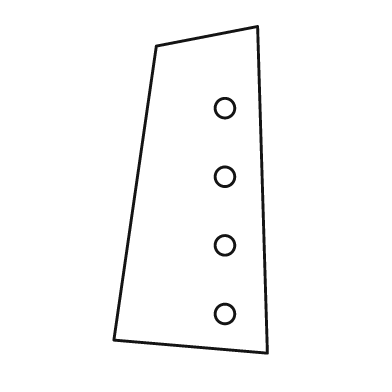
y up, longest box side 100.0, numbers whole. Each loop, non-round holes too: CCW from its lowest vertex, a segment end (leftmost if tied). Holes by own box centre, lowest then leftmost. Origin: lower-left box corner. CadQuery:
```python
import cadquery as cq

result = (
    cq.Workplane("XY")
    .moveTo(47.0, 0.0)
    .lineTo(44.0, 100.0)
    .lineTo(13.0, 94.0)
    .lineTo(0.0, 4.0)
    .close()
    .moveTo(34.0, 12.0)
    .circle(3.0)
    .moveTo(34.0, 33.0)
    .circle(3.0)
    .moveTo(34.0, 54.0)
    .circle(3.0)
    .moveTo(34.0, 75.0)
    .circle(3.0)
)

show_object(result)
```